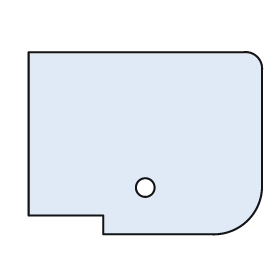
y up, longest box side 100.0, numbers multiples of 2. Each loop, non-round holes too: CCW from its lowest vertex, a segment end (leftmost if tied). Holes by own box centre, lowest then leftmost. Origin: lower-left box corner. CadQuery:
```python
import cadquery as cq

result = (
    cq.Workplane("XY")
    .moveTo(32.0, 0.0)
    .lineTo(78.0, 0.0)
    .threePointArc((94.0, 6.0), (100.0, 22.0))
    .lineTo(100.0, 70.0)
    .threePointArc((98.0, 76.0), (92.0, 78.0))
    .lineTo(0.0, 78.0)
    .lineTo(0.0, 8.0)
    .lineTo(32.0, 8.0)
    .close()
    .moveTo(50.0, 20.0)
    .circle(4.0)
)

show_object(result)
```